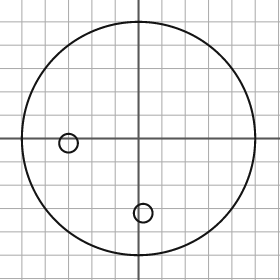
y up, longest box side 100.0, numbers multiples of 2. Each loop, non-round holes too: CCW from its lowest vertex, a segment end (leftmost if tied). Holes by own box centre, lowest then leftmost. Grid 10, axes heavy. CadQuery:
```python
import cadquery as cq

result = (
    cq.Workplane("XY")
    .moveTo(0.0, 0.0)
    .circle(50.0)
    .moveTo(2.0, -32.0)
    .circle(4.0)
    .moveTo(-30.0, -2.0)
    .circle(4.0)
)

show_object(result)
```